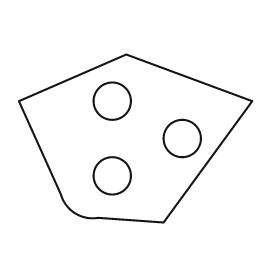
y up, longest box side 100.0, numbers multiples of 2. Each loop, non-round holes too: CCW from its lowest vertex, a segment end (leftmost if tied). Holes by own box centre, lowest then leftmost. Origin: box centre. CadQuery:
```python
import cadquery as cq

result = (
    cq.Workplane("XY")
    .moveTo(12.0, -36.0)
    .lineTo(50.0, 16.0)
    .lineTo(-4.0, 36.0)
    .lineTo(-50.0, 16.0)
    .lineTo(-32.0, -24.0)
    .threePointArc((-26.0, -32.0), (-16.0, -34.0))
    .close()
    .moveTo(-10.0, -16.0)
    .circle(8.0)
    .moveTo(20.0, 0.0)
    .circle(8.0)
    .moveTo(-10.0, 16.0)
    .circle(8.0)
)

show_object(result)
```